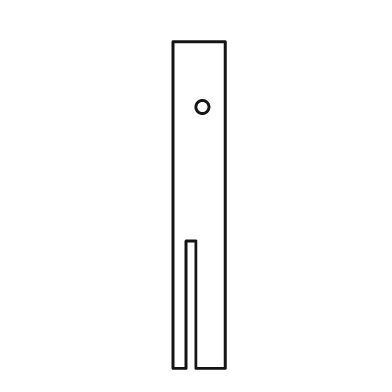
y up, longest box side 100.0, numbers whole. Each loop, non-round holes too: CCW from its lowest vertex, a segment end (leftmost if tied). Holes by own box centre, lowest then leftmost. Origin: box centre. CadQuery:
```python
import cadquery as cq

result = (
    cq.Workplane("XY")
    .moveTo(-8.0, -50.0)
    .lineTo(-4.0, -50.0)
    .lineTo(-4.0, -11.0)
    .lineTo(-1.0, -11.0)
    .lineTo(-1.0, -50.0)
    .lineTo(8.0, -50.0)
    .lineTo(8.0, 50.0)
    .lineTo(-8.0, 50.0)
    .close()
    .moveTo(1.0, 30.0)
    .circle(2.0)
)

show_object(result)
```